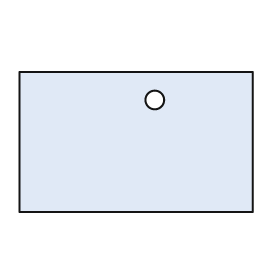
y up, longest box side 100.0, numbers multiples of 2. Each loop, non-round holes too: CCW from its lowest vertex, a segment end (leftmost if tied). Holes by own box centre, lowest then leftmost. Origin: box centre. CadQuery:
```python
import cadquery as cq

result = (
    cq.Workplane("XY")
    .moveTo(-50.0, -30.0)
    .lineTo(50.0, -30.0)
    .lineTo(50.0, 30.0)
    .lineTo(-50.0, 30.0)
    .close()
    .moveTo(8.0, 18.0)
    .circle(4.0)
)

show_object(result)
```